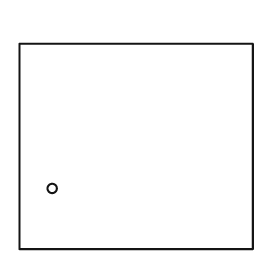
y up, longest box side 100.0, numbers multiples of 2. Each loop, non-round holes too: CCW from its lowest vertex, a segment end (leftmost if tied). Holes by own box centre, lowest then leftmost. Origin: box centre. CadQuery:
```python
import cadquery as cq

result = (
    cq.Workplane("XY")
    .moveTo(-50.0, -44.0)
    .lineTo(50.0, -44.0)
    .lineTo(50.0, 44.0)
    .lineTo(-50.0, 44.0)
    .close()
    .moveTo(-36.0, -18.0)
    .circle(2.0)
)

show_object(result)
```